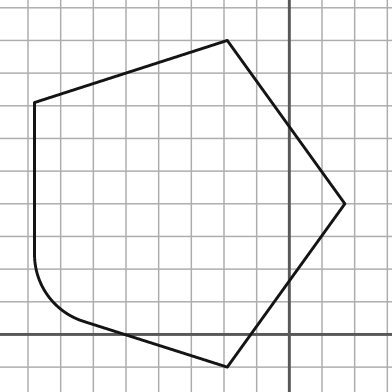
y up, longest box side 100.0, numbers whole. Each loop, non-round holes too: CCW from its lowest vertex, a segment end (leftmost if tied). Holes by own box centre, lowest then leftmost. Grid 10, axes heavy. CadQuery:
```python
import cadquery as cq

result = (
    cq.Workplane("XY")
    .moveTo(-19.0, -10.0)
    .lineTo(17.0, 40.0)
    .lineTo(-19.0, 90.0)
    .lineTo(-78.0, 71.0)
    .lineTo(-78.0, 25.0)
    .threePointArc((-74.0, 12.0), (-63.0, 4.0))
    .close()
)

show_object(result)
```